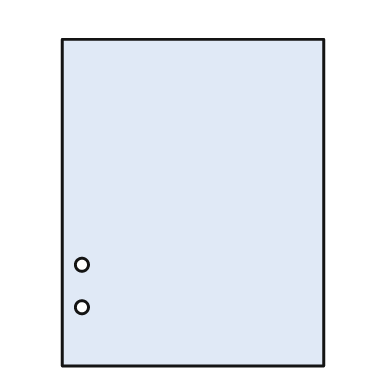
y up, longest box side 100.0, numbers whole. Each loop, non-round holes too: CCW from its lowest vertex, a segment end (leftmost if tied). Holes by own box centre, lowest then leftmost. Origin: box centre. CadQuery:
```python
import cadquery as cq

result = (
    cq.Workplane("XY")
    .moveTo(-40.0, -50.0)
    .lineTo(40.0, -50.0)
    .lineTo(40.0, 50.0)
    .lineTo(-40.0, 50.0)
    .close()
    .moveTo(-34.0, -32.0)
    .circle(2.0)
    .moveTo(-34.0, -19.0)
    .circle(2.0)
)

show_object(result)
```